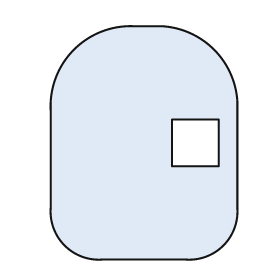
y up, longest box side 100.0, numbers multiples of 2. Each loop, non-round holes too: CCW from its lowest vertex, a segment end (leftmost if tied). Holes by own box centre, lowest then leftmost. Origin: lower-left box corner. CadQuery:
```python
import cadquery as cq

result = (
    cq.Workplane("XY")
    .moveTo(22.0, 0.0)
    .lineTo(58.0, 0.0)
    .threePointArc((74.0, 6.0), (80.0, 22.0))
    .lineTo(80.0, 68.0)
    .threePointArc((70.0, 90.0), (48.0, 100.0))
    .lineTo(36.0, 100.0)
    .threePointArc((10.0, 90.0), (0.0, 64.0))
    .lineTo(0.0, 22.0)
    .threePointArc((6.0, 6.0), (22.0, 0.0))
    .close()
    .moveTo(52.0, 40.0)
    .lineTo(72.0, 40.0)
    .lineTo(72.0, 60.0)
    .lineTo(52.0, 60.0)
    .close()
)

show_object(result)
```